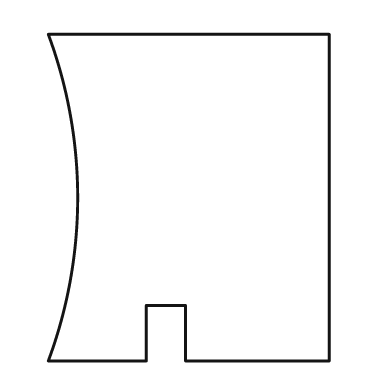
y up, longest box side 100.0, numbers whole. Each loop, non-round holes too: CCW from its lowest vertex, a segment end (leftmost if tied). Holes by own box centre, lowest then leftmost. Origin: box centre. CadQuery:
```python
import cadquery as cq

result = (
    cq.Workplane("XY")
    .moveTo(-43.0, -50.0)
    .lineTo(-13.0, -50.0)
    .lineTo(-13.0, -33.0)
    .lineTo(-1.0, -33.0)
    .lineTo(-1.0, -50.0)
    .lineTo(43.0, -50.0)
    .lineTo(43.0, 50.0)
    .lineTo(-43.0, 50.0)
    .threePointArc((-34.0, 0.0), (-43.0, -50.0))
    .close()
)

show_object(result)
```